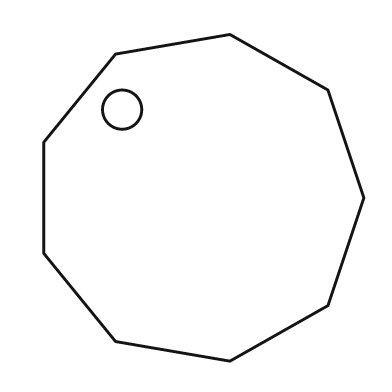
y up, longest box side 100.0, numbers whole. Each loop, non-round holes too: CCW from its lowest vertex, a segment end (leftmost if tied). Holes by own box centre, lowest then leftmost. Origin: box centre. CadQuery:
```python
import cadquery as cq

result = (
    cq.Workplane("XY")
    .moveTo(8.0, -50.0)
    .lineTo(38.0, -33.0)
    .lineTo(49.0, 0.0)
    .lineTo(38.0, 33.0)
    .lineTo(8.0, 50.0)
    .lineTo(-27.0, 44.0)
    .lineTo(-49.0, 17.0)
    .lineTo(-49.0, -17.0)
    .lineTo(-27.0, -44.0)
    .close()
    .moveTo(-25.0, 27.0)
    .circle(6.0)
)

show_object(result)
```